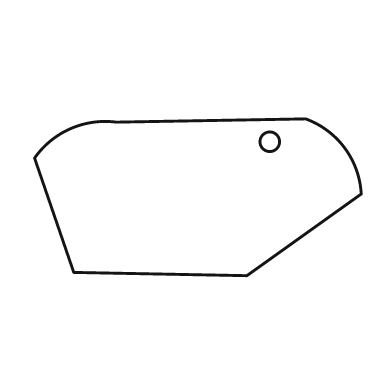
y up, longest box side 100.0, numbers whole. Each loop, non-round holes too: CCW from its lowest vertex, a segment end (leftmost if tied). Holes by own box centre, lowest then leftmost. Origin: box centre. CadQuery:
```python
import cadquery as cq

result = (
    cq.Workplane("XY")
    .moveTo(15.0, -24.0)
    .lineTo(50.0, 1.0)
    .threePointArc((45.0, 15.0), (33.0, 24.0))
    .lineTo(-25.0, 23.0)
    .threePointArc((-39.0, 21.0), (-50.0, 12.0))
    .lineTo(-38.0, -23.0)
    .close()
    .moveTo(22.0, 17.0)
    .circle(3.0)
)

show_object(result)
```